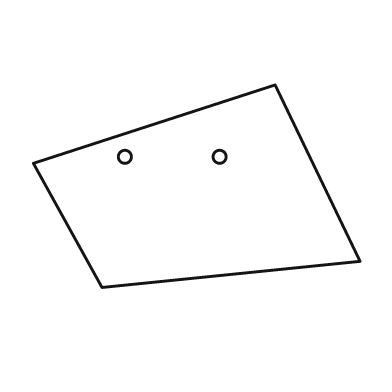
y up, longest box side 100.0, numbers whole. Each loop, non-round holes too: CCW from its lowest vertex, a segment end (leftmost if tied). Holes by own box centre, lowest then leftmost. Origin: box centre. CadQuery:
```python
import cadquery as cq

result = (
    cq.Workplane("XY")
    .moveTo(-29.0, -31.0)
    .lineTo(50.0, -23.0)
    .lineTo(24.0, 31.0)
    .lineTo(-50.0, 7.0)
    .close()
    .moveTo(-22.0, 9.0)
    .circle(2.0)
    .moveTo(7.0, 9.0)
    .circle(2.0)
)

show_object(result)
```